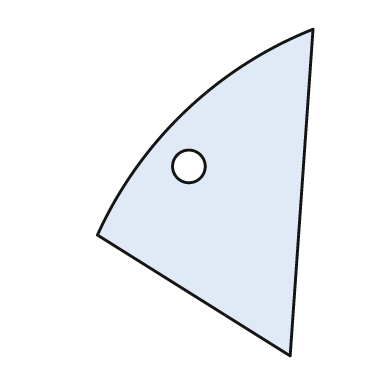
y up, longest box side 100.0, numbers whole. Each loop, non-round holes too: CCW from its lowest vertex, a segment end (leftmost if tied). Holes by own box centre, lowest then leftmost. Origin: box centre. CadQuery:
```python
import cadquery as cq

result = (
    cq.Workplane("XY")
    .moveTo(26.0, -50.0)
    .lineTo(33.0, 50.0)
    .threePointArc((-6.0, 25.0), (-33.0, -13.0))
    .close()
    .moveTo(-5.0, 8.0)
    .circle(5.0)
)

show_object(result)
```